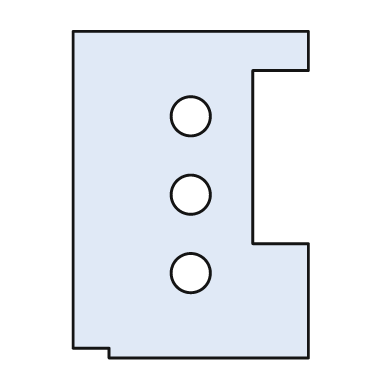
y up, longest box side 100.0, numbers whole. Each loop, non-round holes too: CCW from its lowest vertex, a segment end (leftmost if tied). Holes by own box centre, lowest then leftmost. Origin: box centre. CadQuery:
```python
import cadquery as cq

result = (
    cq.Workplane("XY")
    .moveTo(-25.0, -50.0)
    .lineTo(36.0, -50.0)
    .lineTo(36.0, -15.0)
    .lineTo(19.0, -15.0)
    .lineTo(19.0, 38.0)
    .lineTo(36.0, 38.0)
    .lineTo(36.0, 50.0)
    .lineTo(-36.0, 50.0)
    .lineTo(-36.0, -47.0)
    .lineTo(-25.0, -47.0)
    .close()
    .moveTo(0.0, -24.0)
    .circle(6.0)
    .moveTo(0.0, 0.0)
    .circle(6.0)
    .moveTo(0.0, 24.0)
    .circle(6.0)
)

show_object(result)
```